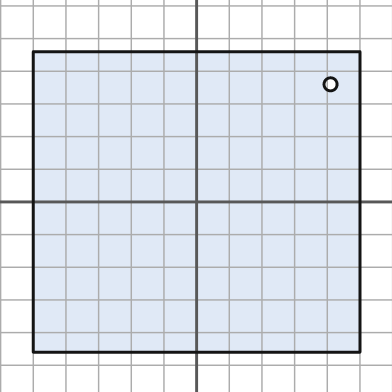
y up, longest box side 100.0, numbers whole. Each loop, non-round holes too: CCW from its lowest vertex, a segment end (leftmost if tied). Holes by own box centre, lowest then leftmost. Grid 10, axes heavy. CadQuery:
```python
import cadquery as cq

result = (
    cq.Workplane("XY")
    .moveTo(-50.0, -46.0)
    .lineTo(50.0, -46.0)
    .lineTo(50.0, 46.0)
    .lineTo(-50.0, 46.0)
    .close()
    .moveTo(41.0, 36.0)
    .circle(2.0)
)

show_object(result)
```